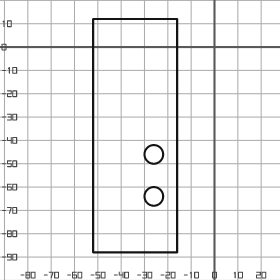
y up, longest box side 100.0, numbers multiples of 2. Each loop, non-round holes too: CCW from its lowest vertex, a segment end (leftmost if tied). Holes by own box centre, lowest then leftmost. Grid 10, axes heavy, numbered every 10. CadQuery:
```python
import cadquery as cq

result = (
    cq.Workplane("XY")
    .moveTo(-52.0, -88.0)
    .lineTo(-16.0, -88.0)
    .lineTo(-16.0, 12.0)
    .lineTo(-52.0, 12.0)
    .close()
    .moveTo(-26.0, -64.0)
    .circle(4.0)
    .moveTo(-26.0, -46.0)
    .circle(4.0)
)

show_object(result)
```